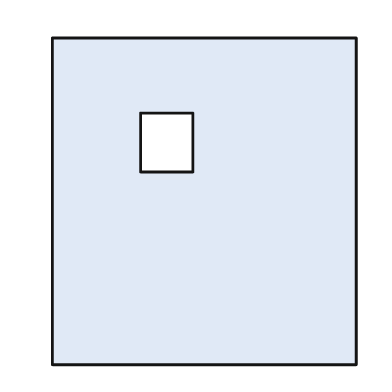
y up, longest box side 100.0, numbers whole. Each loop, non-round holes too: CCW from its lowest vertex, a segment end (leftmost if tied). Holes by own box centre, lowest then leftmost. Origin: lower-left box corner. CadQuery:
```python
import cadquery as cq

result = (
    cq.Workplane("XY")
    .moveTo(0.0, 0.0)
    .lineTo(93.0, 0.0)
    .lineTo(93.0, 100.0)
    .lineTo(0.0, 100.0)
    .close()
    .moveTo(27.0, 59.0)
    .lineTo(43.0, 59.0)
    .lineTo(43.0, 77.0)
    .lineTo(27.0, 77.0)
    .close()
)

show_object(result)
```